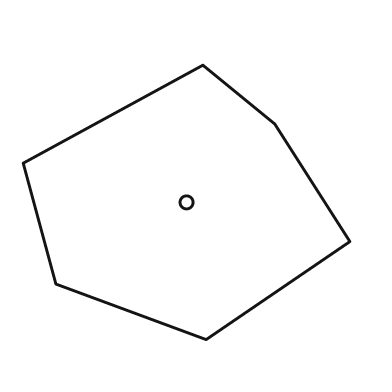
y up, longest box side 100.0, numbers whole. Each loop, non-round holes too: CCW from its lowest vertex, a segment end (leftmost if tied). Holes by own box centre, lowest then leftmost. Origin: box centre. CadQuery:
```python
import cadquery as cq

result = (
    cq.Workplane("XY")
    .moveTo(6.0, -42.0)
    .lineTo(50.0, -12.0)
    .lineTo(27.0, 24.0)
    .lineTo(5.0, 42.0)
    .lineTo(-50.0, 12.0)
    .lineTo(-40.0, -25.0)
    .close()
    .moveTo(0.0, 0.0)
    .circle(2.0)
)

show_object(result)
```